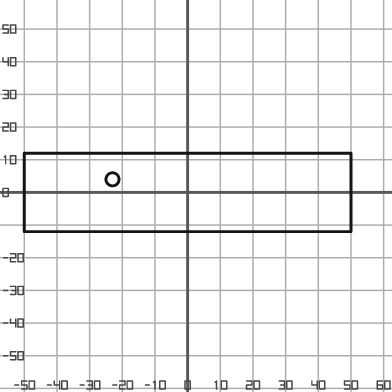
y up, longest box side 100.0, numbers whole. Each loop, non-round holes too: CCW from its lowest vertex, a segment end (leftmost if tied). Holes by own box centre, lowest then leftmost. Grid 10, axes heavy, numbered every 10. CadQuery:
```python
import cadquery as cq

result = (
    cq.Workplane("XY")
    .moveTo(-50.0, -12.0)
    .lineTo(50.0, -12.0)
    .lineTo(50.0, 12.0)
    .lineTo(-50.0, 12.0)
    .close()
    .moveTo(-23.0, 4.0)
    .circle(2.0)
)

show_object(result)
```